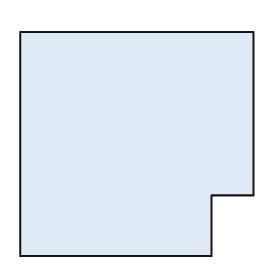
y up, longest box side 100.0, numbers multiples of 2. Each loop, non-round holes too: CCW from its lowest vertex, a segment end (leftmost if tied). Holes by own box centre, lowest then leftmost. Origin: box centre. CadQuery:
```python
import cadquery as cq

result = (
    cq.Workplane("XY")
    .moveTo(-50.0, -48.0)
    .lineTo(32.0, -48.0)
    .lineTo(32.0, -22.0)
    .lineTo(50.0, -22.0)
    .lineTo(50.0, 48.0)
    .lineTo(-50.0, 48.0)
    .close()
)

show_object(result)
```